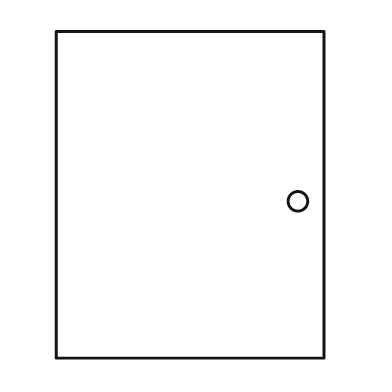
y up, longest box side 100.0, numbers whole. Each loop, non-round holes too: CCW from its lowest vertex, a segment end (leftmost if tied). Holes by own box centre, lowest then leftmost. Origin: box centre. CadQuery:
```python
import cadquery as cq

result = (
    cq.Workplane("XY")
    .moveTo(-41.0, -50.0)
    .lineTo(41.0, -50.0)
    .lineTo(41.0, 50.0)
    .lineTo(-41.0, 50.0)
    .close()
    .moveTo(33.0, -2.0)
    .circle(3.0)
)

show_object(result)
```